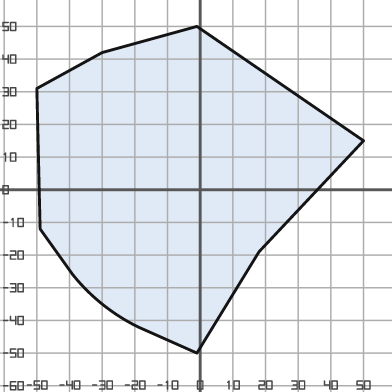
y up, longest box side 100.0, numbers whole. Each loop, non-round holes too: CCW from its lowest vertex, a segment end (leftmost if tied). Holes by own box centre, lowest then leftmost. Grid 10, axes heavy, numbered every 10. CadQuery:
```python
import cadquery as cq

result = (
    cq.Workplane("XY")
    .moveTo(-1.0, -50.0)
    .lineTo(18.0, -19.0)
    .lineTo(50.0, 15.0)
    .lineTo(-1.0, 50.0)
    .lineTo(-30.0, 42.0)
    .lineTo(-50.0, 31.0)
    .lineTo(-49.0, -12.0)
    .lineTo(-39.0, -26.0)
    .threePointArc((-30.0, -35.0), (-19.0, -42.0))
    .close()
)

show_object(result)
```